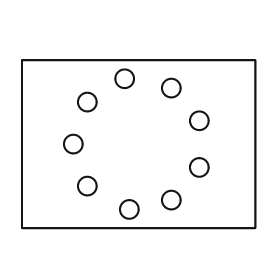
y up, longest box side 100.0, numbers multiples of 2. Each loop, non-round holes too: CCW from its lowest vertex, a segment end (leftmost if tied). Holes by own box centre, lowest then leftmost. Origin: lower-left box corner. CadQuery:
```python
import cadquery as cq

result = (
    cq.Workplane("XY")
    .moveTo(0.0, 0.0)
    .lineTo(100.0, 0.0)
    .lineTo(100.0, 72.0)
    .lineTo(0.0, 72.0)
    .close()
    .moveTo(46.0, 8.0)
    .circle(4.0)
    .moveTo(64.0, 12.0)
    .circle(4.0)
    .moveTo(28.0, 18.0)
    .circle(4.0)
    .moveTo(76.0, 26.0)
    .circle(4.0)
    .moveTo(22.0, 36.0)
    .circle(4.0)
    .moveTo(76.0, 46.0)
    .circle(4.0)
    .moveTo(28.0, 54.0)
    .circle(4.0)
    .moveTo(64.0, 60.0)
    .circle(4.0)
    .moveTo(44.0, 64.0)
    .circle(4.0)
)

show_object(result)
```